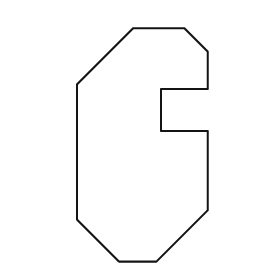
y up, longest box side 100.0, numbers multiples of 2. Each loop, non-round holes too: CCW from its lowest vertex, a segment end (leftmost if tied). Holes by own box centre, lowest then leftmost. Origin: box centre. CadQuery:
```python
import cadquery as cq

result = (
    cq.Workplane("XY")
    .moveTo(-10.0, -50.0)
    .lineTo(6.0, -50.0)
    .lineTo(28.0, -28.0)
    .lineTo(28.0, 6.0)
    .lineTo(8.0, 6.0)
    .lineTo(8.0, 24.0)
    .lineTo(28.0, 24.0)
    .lineTo(28.0, 40.0)
    .lineTo(18.0, 50.0)
    .lineTo(-4.0, 50.0)
    .lineTo(-28.0, 26.0)
    .lineTo(-28.0, -32.0)
    .close()
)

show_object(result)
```